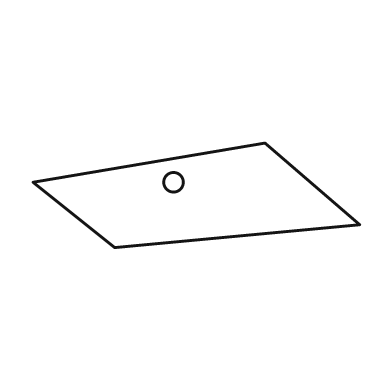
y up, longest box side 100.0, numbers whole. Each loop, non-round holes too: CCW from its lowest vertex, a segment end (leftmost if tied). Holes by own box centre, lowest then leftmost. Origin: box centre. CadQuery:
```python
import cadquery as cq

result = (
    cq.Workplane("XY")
    .moveTo(-25.0, -16.0)
    .lineTo(50.0, -9.0)
    .lineTo(21.0, 16.0)
    .lineTo(-50.0, 4.0)
    .close()
    .moveTo(-7.0, 4.0)
    .circle(3.0)
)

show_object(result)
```